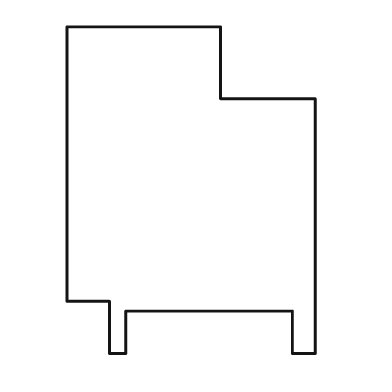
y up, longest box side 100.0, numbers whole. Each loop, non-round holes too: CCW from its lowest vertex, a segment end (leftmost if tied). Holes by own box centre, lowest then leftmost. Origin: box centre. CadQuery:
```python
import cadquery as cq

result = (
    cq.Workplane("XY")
    .moveTo(-25.0, -50.0)
    .lineTo(-20.0, -50.0)
    .lineTo(-20.0, -37.0)
    .lineTo(31.0, -37.0)
    .lineTo(31.0, -50.0)
    .lineTo(38.0, -50.0)
    .lineTo(38.0, 28.0)
    .lineTo(9.0, 28.0)
    .lineTo(9.0, 50.0)
    .lineTo(-38.0, 50.0)
    .lineTo(-38.0, -34.0)
    .lineTo(-25.0, -34.0)
    .close()
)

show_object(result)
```